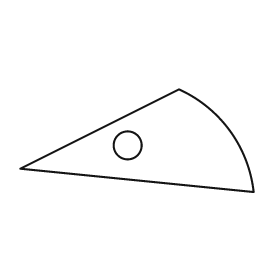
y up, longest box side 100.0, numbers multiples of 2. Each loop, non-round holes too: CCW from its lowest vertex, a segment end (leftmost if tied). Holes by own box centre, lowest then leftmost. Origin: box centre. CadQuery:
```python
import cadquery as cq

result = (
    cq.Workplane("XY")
    .moveTo(50.0, -22.0)
    .threePointArc((40.0, 4.0), (18.0, 22.0))
    .lineTo(-50.0, -12.0)
    .close()
    .moveTo(-4.0, -2.0)
    .circle(6.0)
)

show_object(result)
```